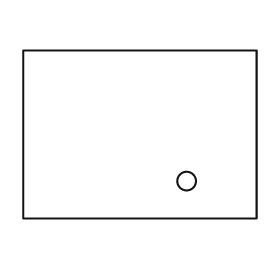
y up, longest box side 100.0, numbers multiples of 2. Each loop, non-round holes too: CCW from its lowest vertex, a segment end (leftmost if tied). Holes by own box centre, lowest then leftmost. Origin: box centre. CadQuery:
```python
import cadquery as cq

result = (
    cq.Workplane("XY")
    .moveTo(-50.0, -36.0)
    .lineTo(50.0, -36.0)
    .lineTo(50.0, 36.0)
    .lineTo(-50.0, 36.0)
    .close()
    .moveTo(20.0, -20.0)
    .circle(4.0)
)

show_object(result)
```